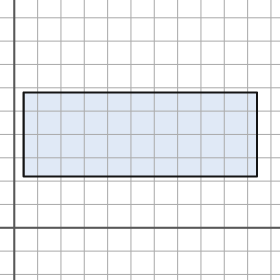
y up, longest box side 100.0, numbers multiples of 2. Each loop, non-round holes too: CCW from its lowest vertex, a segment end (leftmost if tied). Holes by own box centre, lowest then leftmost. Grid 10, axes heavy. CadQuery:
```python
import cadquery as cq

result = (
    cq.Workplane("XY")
    .moveTo(4.0, 22.0)
    .lineTo(104.0, 22.0)
    .lineTo(104.0, 58.0)
    .lineTo(4.0, 58.0)
    .close()
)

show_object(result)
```